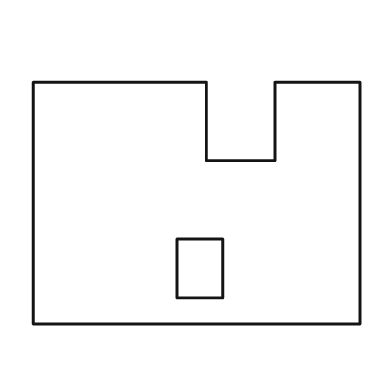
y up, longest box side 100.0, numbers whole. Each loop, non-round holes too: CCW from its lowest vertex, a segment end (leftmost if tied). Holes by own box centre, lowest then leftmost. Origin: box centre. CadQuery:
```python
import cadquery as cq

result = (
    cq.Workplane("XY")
    .moveTo(-50.0, -37.0)
    .lineTo(50.0, -37.0)
    .lineTo(50.0, 37.0)
    .lineTo(24.0, 37.0)
    .lineTo(24.0, 13.0)
    .lineTo(3.0, 13.0)
    .lineTo(3.0, 37.0)
    .lineTo(-50.0, 37.0)
    .close()
    .moveTo(-6.0, -29.0)
    .lineTo(8.0, -29.0)
    .lineTo(8.0, -11.0)
    .lineTo(-6.0, -11.0)
    .close()
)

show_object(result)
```